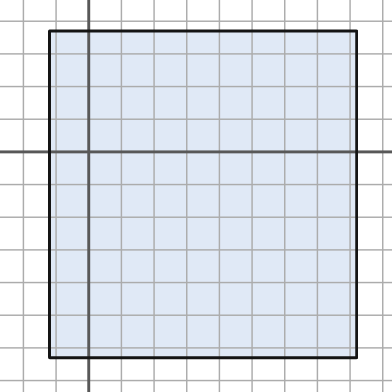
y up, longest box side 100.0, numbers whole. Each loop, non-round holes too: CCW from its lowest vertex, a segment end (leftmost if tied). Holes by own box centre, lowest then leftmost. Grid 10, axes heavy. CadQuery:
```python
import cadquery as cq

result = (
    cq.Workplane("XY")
    .moveTo(-12.0, -63.0)
    .lineTo(82.0, -63.0)
    .lineTo(82.0, 37.0)
    .lineTo(-12.0, 37.0)
    .close()
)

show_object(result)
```